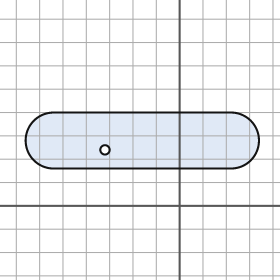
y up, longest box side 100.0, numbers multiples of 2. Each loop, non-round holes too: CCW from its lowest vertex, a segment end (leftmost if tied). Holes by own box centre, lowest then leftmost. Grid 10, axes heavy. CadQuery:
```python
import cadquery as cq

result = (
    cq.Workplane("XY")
    .moveTo(-54.0, 16.0)
    .lineTo(22.0, 16.0)
    .threePointArc((34.0, 28.0), (22.0, 40.0))
    .lineTo(-54.0, 40.0)
    .threePointArc((-66.0, 28.0), (-54.0, 16.0))
    .close()
    .moveTo(-32.0, 24.0)
    .circle(2.0)
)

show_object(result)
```